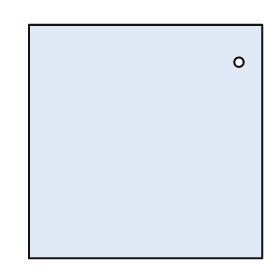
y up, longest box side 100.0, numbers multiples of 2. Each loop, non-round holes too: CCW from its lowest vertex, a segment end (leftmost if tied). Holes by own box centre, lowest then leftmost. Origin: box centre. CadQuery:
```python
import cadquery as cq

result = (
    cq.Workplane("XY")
    .moveTo(-50.0, -50.0)
    .lineTo(50.0, -50.0)
    .lineTo(50.0, 50.0)
    .lineTo(-50.0, 50.0)
    .close()
    .moveTo(40.0, 34.0)
    .circle(2.0)
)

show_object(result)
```